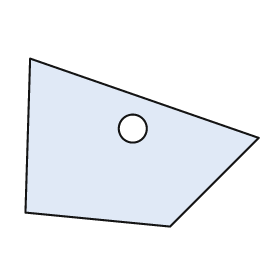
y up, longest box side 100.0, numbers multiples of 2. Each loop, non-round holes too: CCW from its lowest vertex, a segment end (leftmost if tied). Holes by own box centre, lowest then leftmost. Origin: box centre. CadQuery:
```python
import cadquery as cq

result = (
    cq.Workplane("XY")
    .moveTo(12.0, -36.0)
    .lineTo(50.0, 2.0)
    .lineTo(-48.0, 36.0)
    .lineTo(-50.0, -30.0)
    .close()
    .moveTo(-4.0, 6.0)
    .circle(6.0)
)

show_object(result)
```